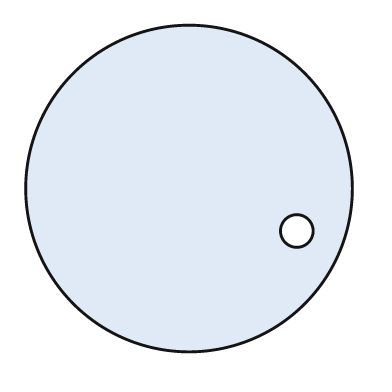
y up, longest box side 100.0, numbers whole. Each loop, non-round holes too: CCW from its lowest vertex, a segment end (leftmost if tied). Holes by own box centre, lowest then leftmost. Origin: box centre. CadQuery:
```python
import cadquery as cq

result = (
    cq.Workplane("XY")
    .moveTo(0.0, 0.0)
    .circle(50.0)
    .moveTo(33.0, -13.0)
    .circle(5.0)
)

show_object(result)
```